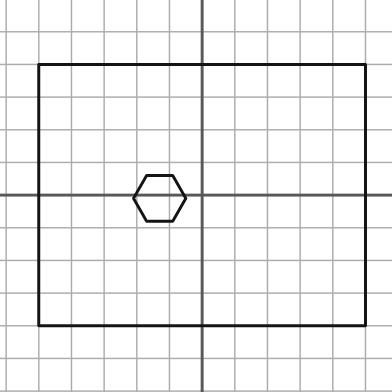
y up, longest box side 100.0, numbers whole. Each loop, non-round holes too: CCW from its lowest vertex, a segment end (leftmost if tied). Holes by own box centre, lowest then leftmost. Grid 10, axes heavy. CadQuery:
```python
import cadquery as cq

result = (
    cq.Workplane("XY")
    .moveTo(-50.0, -40.0)
    .lineTo(50.0, -40.0)
    .lineTo(50.0, 40.0)
    .lineTo(-50.0, 40.0)
    .close()
    .moveTo(-17.0, -8.0)
    .lineTo(-9.0, -8.0)
    .lineTo(-5.0, -1.0)
    .lineTo(-9.0, 6.0)
    .lineTo(-17.0, 6.0)
    .lineTo(-21.0, -1.0)
    .close()
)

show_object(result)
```